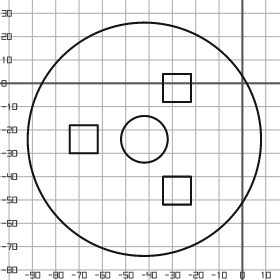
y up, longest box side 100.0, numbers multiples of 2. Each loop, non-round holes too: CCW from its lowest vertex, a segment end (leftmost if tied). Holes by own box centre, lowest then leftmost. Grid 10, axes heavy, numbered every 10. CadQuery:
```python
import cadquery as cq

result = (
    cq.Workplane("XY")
    .moveTo(-42.0, -24.0)
    .circle(50.0)
    .moveTo(-34.0, -52.0)
    .lineTo(-22.0, -52.0)
    .lineTo(-22.0, -40.0)
    .lineTo(-34.0, -40.0)
    .close()
    .moveTo(-74.0, -30.0)
    .lineTo(-62.0, -30.0)
    .lineTo(-62.0, -18.0)
    .lineTo(-74.0, -18.0)
    .close()
    .moveTo(-42.0, -24.0)
    .circle(10.0)
    .moveTo(-34.0, -8.0)
    .lineTo(-22.0, -8.0)
    .lineTo(-22.0, 4.0)
    .lineTo(-34.0, 4.0)
    .close()
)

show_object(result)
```